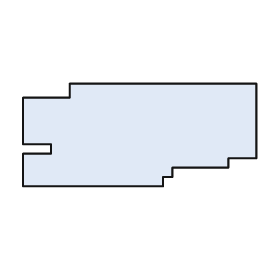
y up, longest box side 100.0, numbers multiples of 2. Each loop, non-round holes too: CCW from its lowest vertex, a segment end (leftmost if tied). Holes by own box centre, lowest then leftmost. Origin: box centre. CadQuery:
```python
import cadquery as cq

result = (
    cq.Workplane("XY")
    .moveTo(-50.0, -22.0)
    .lineTo(10.0, -22.0)
    .lineTo(10.0, -18.0)
    .lineTo(14.0, -18.0)
    .lineTo(14.0, -14.0)
    .lineTo(38.0, -14.0)
    .lineTo(38.0, -10.0)
    .lineTo(50.0, -10.0)
    .lineTo(50.0, 22.0)
    .lineTo(-30.0, 22.0)
    .lineTo(-30.0, 16.0)
    .lineTo(-50.0, 16.0)
    .lineTo(-50.0, -4.0)
    .lineTo(-38.0, -4.0)
    .lineTo(-38.0, -8.0)
    .lineTo(-50.0, -8.0)
    .close()
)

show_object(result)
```